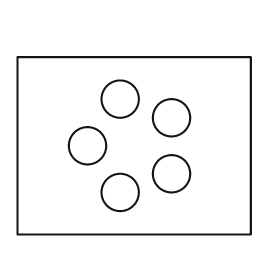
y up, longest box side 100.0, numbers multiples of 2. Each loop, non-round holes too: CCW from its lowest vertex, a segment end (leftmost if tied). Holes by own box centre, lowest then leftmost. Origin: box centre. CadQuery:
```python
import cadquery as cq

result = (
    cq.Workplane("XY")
    .moveTo(-50.0, -38.0)
    .lineTo(50.0, -38.0)
    .lineTo(50.0, 38.0)
    .lineTo(-50.0, 38.0)
    .close()
    .moveTo(-6.0, -20.0)
    .circle(8.0)
    .moveTo(16.0, -12.0)
    .circle(8.0)
    .moveTo(-20.0, 0.0)
    .circle(8.0)
    .moveTo(16.0, 12.0)
    .circle(8.0)
    .moveTo(-6.0, 20.0)
    .circle(8.0)
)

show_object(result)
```